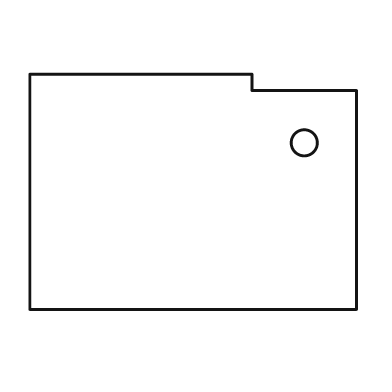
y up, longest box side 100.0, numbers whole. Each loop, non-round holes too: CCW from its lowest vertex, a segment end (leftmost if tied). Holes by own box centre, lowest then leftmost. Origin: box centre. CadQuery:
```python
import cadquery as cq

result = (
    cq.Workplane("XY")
    .moveTo(-50.0, -36.0)
    .lineTo(50.0, -36.0)
    .lineTo(50.0, 31.0)
    .lineTo(18.0, 31.0)
    .lineTo(18.0, 36.0)
    .lineTo(-50.0, 36.0)
    .close()
    .moveTo(34.0, 15.0)
    .circle(4.0)
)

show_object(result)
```